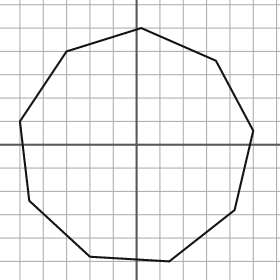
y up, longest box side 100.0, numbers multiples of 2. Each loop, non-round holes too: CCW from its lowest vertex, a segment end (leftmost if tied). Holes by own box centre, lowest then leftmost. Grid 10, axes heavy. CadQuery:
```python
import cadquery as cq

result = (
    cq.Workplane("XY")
    .moveTo(14.0, -50.0)
    .lineTo(42.0, -28.0)
    .lineTo(50.0, 6.0)
    .lineTo(34.0, 36.0)
    .lineTo(2.0, 50.0)
    .lineTo(-30.0, 40.0)
    .lineTo(-50.0, 10.0)
    .lineTo(-46.0, -24.0)
    .lineTo(-20.0, -48.0)
    .close()
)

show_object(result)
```